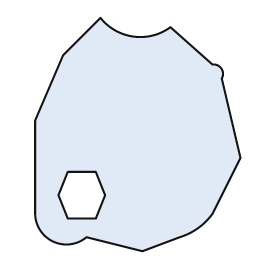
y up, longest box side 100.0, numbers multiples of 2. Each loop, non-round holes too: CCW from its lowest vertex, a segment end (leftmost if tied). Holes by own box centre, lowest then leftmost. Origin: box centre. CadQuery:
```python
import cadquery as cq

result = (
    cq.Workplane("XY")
    .moveTo(2.0, -50.0)
    .lineTo(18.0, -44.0)
    .threePointArc((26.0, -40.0), (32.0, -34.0))
    .lineTo(44.0, -10.0)
    .lineTo(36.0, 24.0)
    .threePointArc((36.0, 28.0), (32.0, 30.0))
    .lineTo(14.0, 46.0)
    .threePointArc((-2.0, 42.0), (-16.0, 50.0))
    .lineTo(-32.0, 34.0)
    .lineTo(-44.0, 6.0)
    .lineTo(-44.0, -34.0)
    .threePointArc((-36.0, -46.0), (-22.0, -44.0))
    .close()
    .moveTo(-30.0, -36.0)
    .lineTo(-18.0, -36.0)
    .lineTo(-14.0, -26.0)
    .lineTo(-18.0, -16.0)
    .lineTo(-30.0, -16.0)
    .lineTo(-34.0, -26.0)
    .close()
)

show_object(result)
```